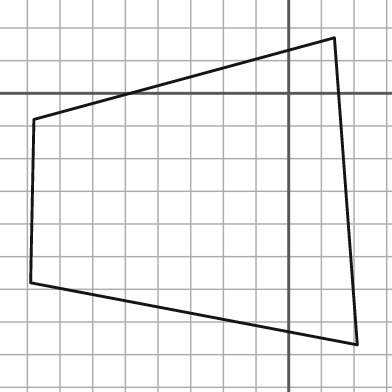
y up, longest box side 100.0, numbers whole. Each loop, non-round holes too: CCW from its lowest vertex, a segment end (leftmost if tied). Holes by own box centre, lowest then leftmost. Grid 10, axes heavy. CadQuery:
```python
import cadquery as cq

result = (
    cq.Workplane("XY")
    .moveTo(21.0, -77.0)
    .lineTo(14.0, 17.0)
    .lineTo(-78.0, -8.0)
    .lineTo(-79.0, -58.0)
    .close()
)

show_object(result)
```